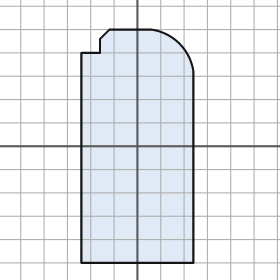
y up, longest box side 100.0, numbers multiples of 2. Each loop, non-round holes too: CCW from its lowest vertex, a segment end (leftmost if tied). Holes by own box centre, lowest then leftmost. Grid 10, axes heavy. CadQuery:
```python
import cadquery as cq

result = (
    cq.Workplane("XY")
    .moveTo(-24.0, -50.0)
    .lineTo(24.0, -50.0)
    .lineTo(24.0, 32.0)
    .threePointArc((18.0, 44.0), (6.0, 50.0))
    .lineTo(-12.0, 50.0)
    .lineTo(-16.0, 46.0)
    .lineTo(-16.0, 40.0)
    .lineTo(-24.0, 40.0)
    .close()
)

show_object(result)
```